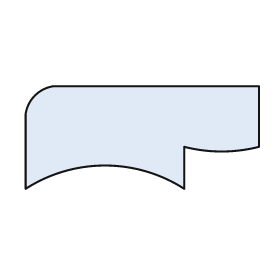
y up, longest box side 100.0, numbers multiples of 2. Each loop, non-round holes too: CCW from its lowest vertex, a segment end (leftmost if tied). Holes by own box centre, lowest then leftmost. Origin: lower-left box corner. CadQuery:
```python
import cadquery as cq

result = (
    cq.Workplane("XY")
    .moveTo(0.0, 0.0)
    .threePointArc((34.0, 10.0), (68.0, 0.0))
    .lineTo(68.0, 18.0)
    .threePointArc((84.0, 16.0), (100.0, 18.0))
    .lineTo(100.0, 44.0)
    .lineTo(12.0, 44.0)
    .threePointArc((4.0, 40.0), (0.0, 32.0))
    .close()
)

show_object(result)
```